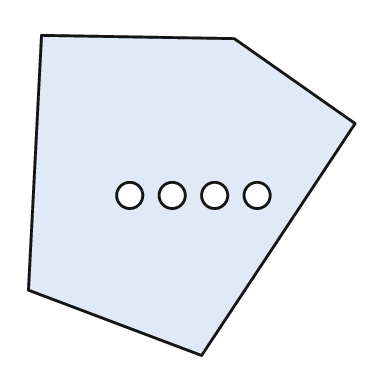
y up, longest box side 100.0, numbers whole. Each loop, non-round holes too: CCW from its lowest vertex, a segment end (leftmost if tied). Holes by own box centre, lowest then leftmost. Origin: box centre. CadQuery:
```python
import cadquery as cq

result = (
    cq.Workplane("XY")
    .moveTo(3.0, -49.0)
    .lineTo(50.0, 22.0)
    .lineTo(13.0, 48.0)
    .lineTo(-46.0, 49.0)
    .lineTo(-50.0, -29.0)
    .close()
    .moveTo(-19.0, 0.0)
    .circle(4.0)
    .moveTo(-6.0, 0.0)
    .circle(4.0)
    .moveTo(7.0, 0.0)
    .circle(4.0)
    .moveTo(20.0, 0.0)
    .circle(4.0)
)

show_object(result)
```